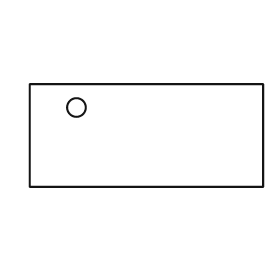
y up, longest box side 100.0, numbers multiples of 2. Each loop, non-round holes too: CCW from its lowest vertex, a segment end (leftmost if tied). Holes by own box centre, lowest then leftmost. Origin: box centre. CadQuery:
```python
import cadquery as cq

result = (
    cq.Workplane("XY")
    .moveTo(-50.0, -22.0)
    .lineTo(50.0, -22.0)
    .lineTo(50.0, 22.0)
    .lineTo(-50.0, 22.0)
    .close()
    .moveTo(-30.0, 12.0)
    .circle(4.0)
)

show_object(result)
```